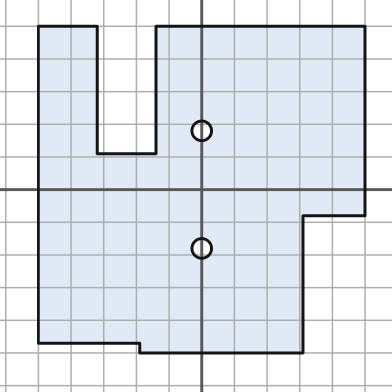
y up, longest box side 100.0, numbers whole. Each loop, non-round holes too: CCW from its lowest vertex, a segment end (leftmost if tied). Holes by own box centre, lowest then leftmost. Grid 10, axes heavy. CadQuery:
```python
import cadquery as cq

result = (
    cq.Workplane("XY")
    .moveTo(-19.0, -50.0)
    .lineTo(31.0, -50.0)
    .lineTo(31.0, -8.0)
    .lineTo(50.0, -8.0)
    .lineTo(50.0, 50.0)
    .lineTo(-14.0, 50.0)
    .lineTo(-14.0, 11.0)
    .lineTo(-32.0, 11.0)
    .lineTo(-32.0, 50.0)
    .lineTo(-50.0, 50.0)
    .lineTo(-50.0, -47.0)
    .lineTo(-19.0, -47.0)
    .close()
    .moveTo(0.0, -18.0)
    .circle(3.0)
    .moveTo(0.0, 18.0)
    .circle(3.0)
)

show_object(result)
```